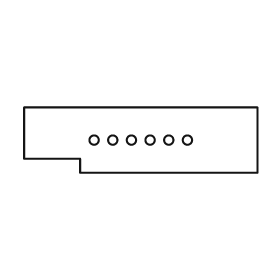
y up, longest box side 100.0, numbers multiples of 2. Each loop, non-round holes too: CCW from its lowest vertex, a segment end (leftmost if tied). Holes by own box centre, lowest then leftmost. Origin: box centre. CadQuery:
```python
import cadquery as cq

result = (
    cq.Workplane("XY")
    .moveTo(-26.0, -14.0)
    .lineTo(50.0, -14.0)
    .lineTo(50.0, 14.0)
    .lineTo(-50.0, 14.0)
    .lineTo(-50.0, -8.0)
    .lineTo(-26.0, -8.0)
    .close()
    .moveTo(-20.0, 0.0)
    .circle(2.0)
    .moveTo(-12.0, 0.0)
    .circle(2.0)
    .moveTo(-4.0, 0.0)
    .circle(2.0)
    .moveTo(4.0, 0.0)
    .circle(2.0)
    .moveTo(12.0, 0.0)
    .circle(2.0)
    .moveTo(20.0, 0.0)
    .circle(2.0)
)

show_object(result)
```